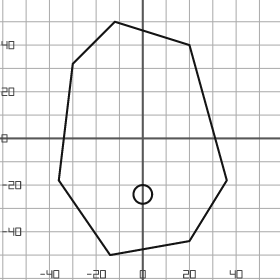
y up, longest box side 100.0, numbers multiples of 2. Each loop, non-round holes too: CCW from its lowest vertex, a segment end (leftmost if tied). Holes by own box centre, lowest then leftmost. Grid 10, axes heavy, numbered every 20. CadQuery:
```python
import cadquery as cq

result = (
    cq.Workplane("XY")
    .moveTo(-14.0, -50.0)
    .lineTo(20.0, -44.0)
    .lineTo(36.0, -18.0)
    .lineTo(20.0, 40.0)
    .lineTo(-12.0, 50.0)
    .lineTo(-30.0, 32.0)
    .lineTo(-36.0, -18.0)
    .close()
    .moveTo(0.0, -24.0)
    .circle(4.0)
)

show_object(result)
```